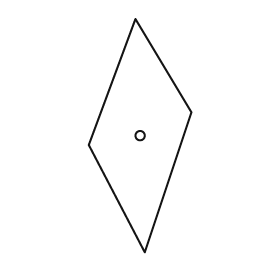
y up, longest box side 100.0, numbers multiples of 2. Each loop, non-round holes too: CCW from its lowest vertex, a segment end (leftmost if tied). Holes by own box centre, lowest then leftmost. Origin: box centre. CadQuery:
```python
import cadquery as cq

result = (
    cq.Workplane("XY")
    .moveTo(2.0, -50.0)
    .lineTo(22.0, 10.0)
    .lineTo(-2.0, 50.0)
    .lineTo(-22.0, -4.0)
    .close()
    .moveTo(0.0, 0.0)
    .circle(2.0)
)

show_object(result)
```